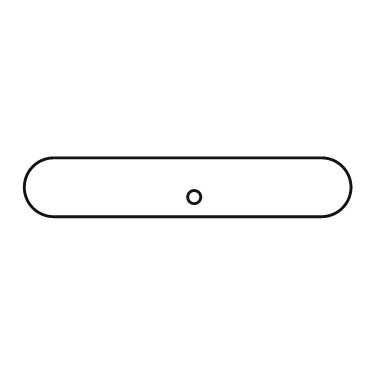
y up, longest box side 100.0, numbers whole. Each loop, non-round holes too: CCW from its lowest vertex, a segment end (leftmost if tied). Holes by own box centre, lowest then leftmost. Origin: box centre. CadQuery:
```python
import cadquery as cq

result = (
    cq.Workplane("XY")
    .moveTo(-41.0, -9.0)
    .lineTo(41.0, -9.0)
    .threePointArc((50.0, 0.0), (41.0, 9.0))
    .lineTo(-41.0, 9.0)
    .threePointArc((-50.0, 0.0), (-41.0, -9.0))
    .close()
    .moveTo(2.0, -3.0)
    .circle(2.0)
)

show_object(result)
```